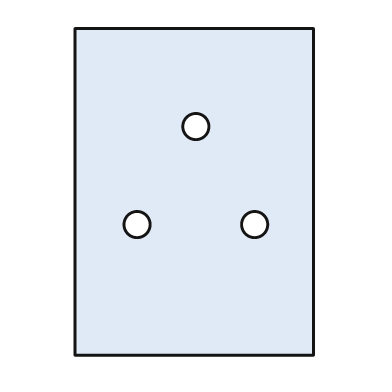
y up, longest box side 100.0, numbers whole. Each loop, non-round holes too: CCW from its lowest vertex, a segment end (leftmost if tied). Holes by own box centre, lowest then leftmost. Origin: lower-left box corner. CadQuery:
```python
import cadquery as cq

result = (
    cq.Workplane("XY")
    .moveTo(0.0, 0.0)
    .lineTo(73.0, 0.0)
    .lineTo(73.0, 100.0)
    .lineTo(0.0, 100.0)
    .close()
    .moveTo(19.0, 40.0)
    .circle(4.0)
    .moveTo(55.0, 40.0)
    .circle(4.0)
    .moveTo(37.0, 70.0)
    .circle(4.0)
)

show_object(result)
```